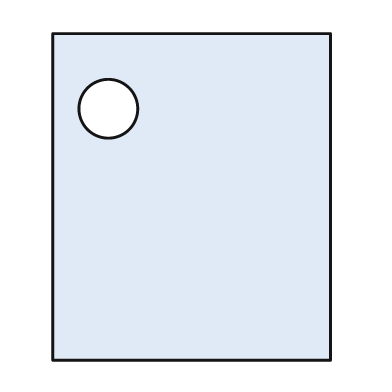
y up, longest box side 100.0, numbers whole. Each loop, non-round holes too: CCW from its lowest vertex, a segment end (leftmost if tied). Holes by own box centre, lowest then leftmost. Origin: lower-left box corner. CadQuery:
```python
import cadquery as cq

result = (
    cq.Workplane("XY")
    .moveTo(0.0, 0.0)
    .lineTo(85.0, 0.0)
    .lineTo(85.0, 100.0)
    .lineTo(0.0, 100.0)
    .close()
    .moveTo(17.0, 77.0)
    .circle(9.0)
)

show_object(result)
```